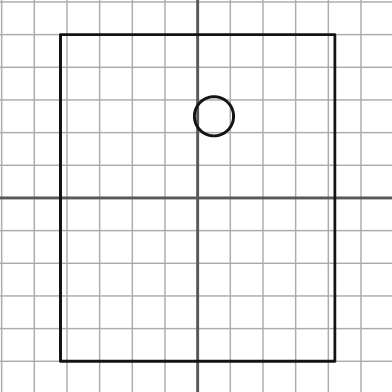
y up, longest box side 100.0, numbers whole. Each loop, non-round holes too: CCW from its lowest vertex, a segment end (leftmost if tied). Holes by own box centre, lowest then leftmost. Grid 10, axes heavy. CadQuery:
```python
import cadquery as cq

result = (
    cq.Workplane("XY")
    .moveTo(-42.0, -50.0)
    .lineTo(42.0, -50.0)
    .lineTo(42.0, 50.0)
    .lineTo(-42.0, 50.0)
    .close()
    .moveTo(5.0, 25.0)
    .circle(6.0)
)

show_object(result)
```